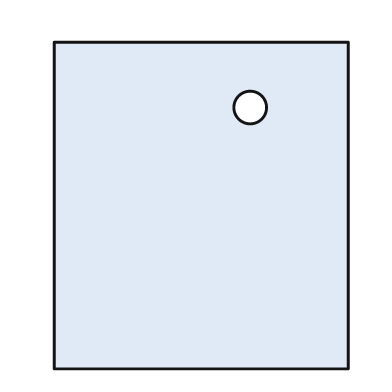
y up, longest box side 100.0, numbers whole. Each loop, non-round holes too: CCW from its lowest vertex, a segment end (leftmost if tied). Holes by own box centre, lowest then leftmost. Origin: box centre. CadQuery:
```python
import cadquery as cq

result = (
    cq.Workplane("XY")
    .moveTo(-45.0, -50.0)
    .lineTo(45.0, -50.0)
    .lineTo(45.0, 50.0)
    .lineTo(-45.0, 50.0)
    .close()
    .moveTo(15.0, 30.0)
    .circle(5.0)
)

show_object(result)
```